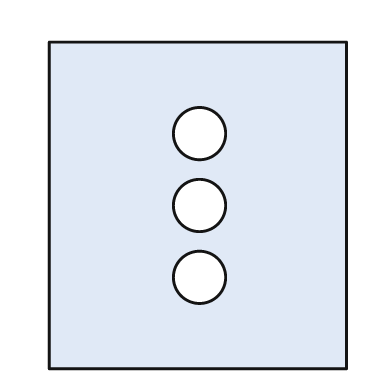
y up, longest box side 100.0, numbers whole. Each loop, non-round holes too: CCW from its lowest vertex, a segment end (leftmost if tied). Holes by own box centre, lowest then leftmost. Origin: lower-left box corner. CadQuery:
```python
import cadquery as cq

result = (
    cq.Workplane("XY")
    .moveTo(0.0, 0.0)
    .lineTo(91.0, 0.0)
    .lineTo(91.0, 100.0)
    .lineTo(0.0, 100.0)
    .close()
    .moveTo(46.0, 28.0)
    .circle(8.0)
    .moveTo(46.0, 50.0)
    .circle(8.0)
    .moveTo(46.0, 72.0)
    .circle(8.0)
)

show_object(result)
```